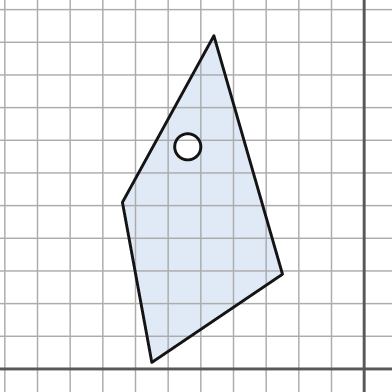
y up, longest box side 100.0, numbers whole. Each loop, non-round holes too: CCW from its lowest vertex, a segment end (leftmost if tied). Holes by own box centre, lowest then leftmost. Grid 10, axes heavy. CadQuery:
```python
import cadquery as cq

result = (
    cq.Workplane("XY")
    .moveTo(-65.0, 2.0)
    .lineTo(-25.0, 29.0)
    .lineTo(-46.0, 102.0)
    .lineTo(-74.0, 51.0)
    .close()
    .moveTo(-54.0, 68.0)
    .circle(4.0)
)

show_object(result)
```